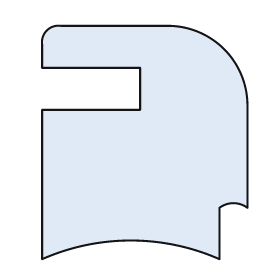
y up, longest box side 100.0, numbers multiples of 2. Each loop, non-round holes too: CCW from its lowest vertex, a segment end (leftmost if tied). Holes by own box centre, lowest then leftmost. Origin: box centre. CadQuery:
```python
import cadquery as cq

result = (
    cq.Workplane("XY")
    .moveTo(-44.0, -50.0)
    .threePointArc((-6.0, -42.0), (32.0, -50.0))
    .lineTo(32.0, -28.0)
    .threePointArc((38.0, -26.0), (44.0, -28.0))
    .lineTo(44.0, 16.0)
    .threePointArc((34.0, 40.0), (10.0, 50.0))
    .lineTo(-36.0, 50.0)
    .threePointArc((-42.0, 48.0), (-44.0, 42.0))
    .lineTo(-44.0, 32.0)
    .lineTo(-2.0, 32.0)
    .lineTo(-2.0, 14.0)
    .lineTo(-44.0, 14.0)
    .close()
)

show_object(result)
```